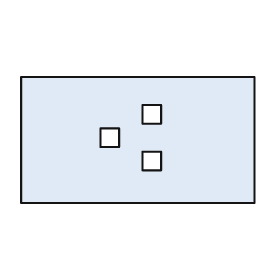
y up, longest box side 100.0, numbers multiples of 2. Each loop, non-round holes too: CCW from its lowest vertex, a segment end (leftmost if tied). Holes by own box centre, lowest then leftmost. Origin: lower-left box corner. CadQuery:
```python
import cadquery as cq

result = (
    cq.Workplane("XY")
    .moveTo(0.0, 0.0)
    .lineTo(100.0, 0.0)
    .lineTo(100.0, 54.0)
    .lineTo(0.0, 54.0)
    .close()
    .moveTo(52.0, 14.0)
    .lineTo(60.0, 14.0)
    .lineTo(60.0, 22.0)
    .lineTo(52.0, 22.0)
    .close()
    .moveTo(34.0, 24.0)
    .lineTo(42.0, 24.0)
    .lineTo(42.0, 32.0)
    .lineTo(34.0, 32.0)
    .close()
    .moveTo(52.0, 34.0)
    .lineTo(60.0, 34.0)
    .lineTo(60.0, 42.0)
    .lineTo(52.0, 42.0)
    .close()
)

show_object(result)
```